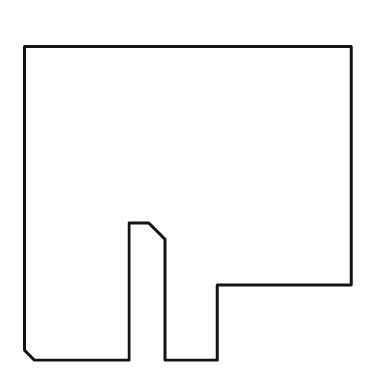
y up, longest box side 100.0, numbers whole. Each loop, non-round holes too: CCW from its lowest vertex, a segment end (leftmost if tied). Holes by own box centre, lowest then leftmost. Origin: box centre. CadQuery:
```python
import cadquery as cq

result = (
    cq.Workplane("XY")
    .moveTo(-47.0, -48.0)
    .lineTo(-18.0, -48.0)
    .lineTo(-18.0, -6.0)
    .lineTo(-12.0, -6.0)
    .lineTo(-7.0, -11.0)
    .lineTo(-7.0, -48.0)
    .lineTo(9.0, -48.0)
    .lineTo(9.0, -25.0)
    .lineTo(50.0, -25.0)
    .lineTo(50.0, 48.0)
    .lineTo(-50.0, 48.0)
    .lineTo(-50.0, -45.0)
    .close()
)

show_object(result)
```